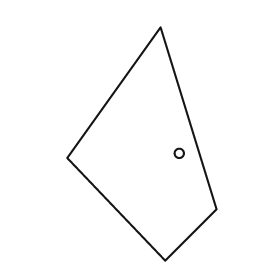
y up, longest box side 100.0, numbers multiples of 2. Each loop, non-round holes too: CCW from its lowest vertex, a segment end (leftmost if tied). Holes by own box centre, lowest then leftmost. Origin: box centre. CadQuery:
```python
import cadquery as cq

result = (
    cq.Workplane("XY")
    .moveTo(10.0, -50.0)
    .lineTo(32.0, -28.0)
    .lineTo(8.0, 50.0)
    .lineTo(-32.0, -6.0)
    .close()
    .moveTo(16.0, -4.0)
    .circle(2.0)
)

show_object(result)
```